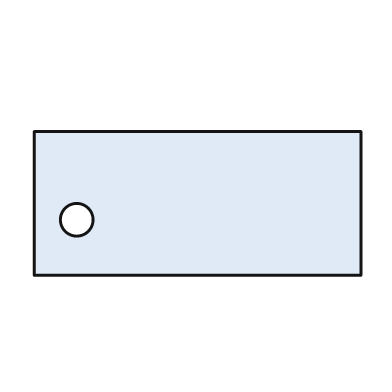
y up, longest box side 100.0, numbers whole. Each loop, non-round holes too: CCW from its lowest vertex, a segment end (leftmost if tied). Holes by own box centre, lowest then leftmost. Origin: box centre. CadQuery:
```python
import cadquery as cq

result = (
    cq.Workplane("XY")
    .moveTo(-50.0, -22.0)
    .lineTo(50.0, -22.0)
    .lineTo(50.0, 22.0)
    .lineTo(-50.0, 22.0)
    .close()
    .moveTo(-37.0, -5.0)
    .circle(5.0)
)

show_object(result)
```